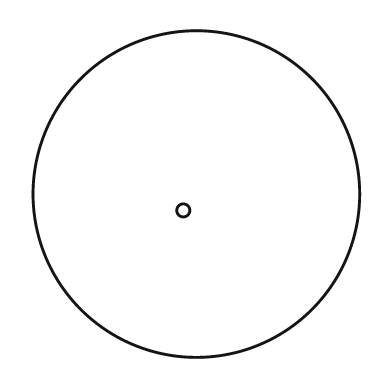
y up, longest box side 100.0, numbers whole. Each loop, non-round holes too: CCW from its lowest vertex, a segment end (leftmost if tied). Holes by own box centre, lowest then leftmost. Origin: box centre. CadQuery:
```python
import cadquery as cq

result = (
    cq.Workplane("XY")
    .moveTo(0.0, 0.0)
    .circle(50.0)
    .moveTo(-4.0, -5.0)
    .circle(2.0)
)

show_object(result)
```